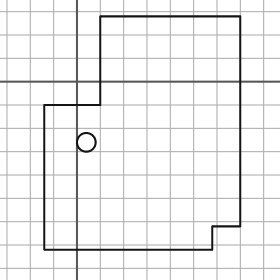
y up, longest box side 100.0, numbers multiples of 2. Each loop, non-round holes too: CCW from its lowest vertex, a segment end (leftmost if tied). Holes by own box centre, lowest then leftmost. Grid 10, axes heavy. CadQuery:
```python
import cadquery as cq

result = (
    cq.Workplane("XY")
    .moveTo(-14.0, -72.0)
    .lineTo(58.0, -72.0)
    .lineTo(58.0, -62.0)
    .lineTo(70.0, -62.0)
    .lineTo(70.0, 28.0)
    .lineTo(10.0, 28.0)
    .lineTo(10.0, -10.0)
    .lineTo(-14.0, -10.0)
    .close()
    .moveTo(4.0, -26.0)
    .circle(4.0)
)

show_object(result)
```